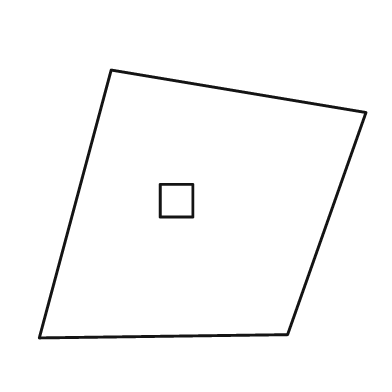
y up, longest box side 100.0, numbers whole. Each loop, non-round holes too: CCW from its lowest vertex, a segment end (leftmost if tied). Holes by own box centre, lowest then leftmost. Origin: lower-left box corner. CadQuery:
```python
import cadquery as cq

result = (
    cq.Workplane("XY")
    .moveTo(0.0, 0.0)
    .lineTo(76.0, 1.0)
    .lineTo(100.0, 69.0)
    .lineTo(22.0, 82.0)
    .close()
    .moveTo(37.0, 37.0)
    .lineTo(47.0, 37.0)
    .lineTo(47.0, 47.0)
    .lineTo(37.0, 47.0)
    .close()
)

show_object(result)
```